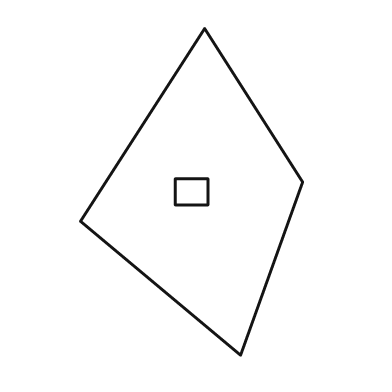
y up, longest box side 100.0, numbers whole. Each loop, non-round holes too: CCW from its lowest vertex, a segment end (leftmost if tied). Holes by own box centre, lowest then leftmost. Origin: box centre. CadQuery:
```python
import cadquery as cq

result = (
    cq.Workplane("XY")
    .moveTo(15.0, -50.0)
    .lineTo(34.0, 3.0)
    .lineTo(4.0, 50.0)
    .lineTo(-34.0, -9.0)
    .close()
    .moveTo(-5.0, -4.0)
    .lineTo(5.0, -4.0)
    .lineTo(5.0, 4.0)
    .lineTo(-5.0, 4.0)
    .close()
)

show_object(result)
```